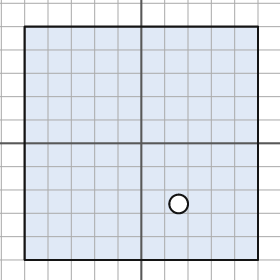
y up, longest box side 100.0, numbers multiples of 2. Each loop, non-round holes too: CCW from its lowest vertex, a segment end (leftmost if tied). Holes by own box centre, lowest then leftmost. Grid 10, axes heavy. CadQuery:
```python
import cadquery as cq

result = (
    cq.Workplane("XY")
    .moveTo(-50.0, -50.0)
    .lineTo(50.0, -50.0)
    .lineTo(50.0, 50.0)
    .lineTo(-50.0, 50.0)
    .close()
    .moveTo(16.0, -26.0)
    .circle(4.0)
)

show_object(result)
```